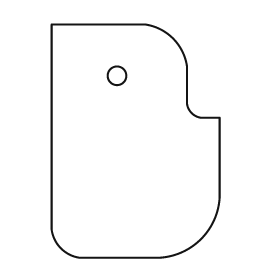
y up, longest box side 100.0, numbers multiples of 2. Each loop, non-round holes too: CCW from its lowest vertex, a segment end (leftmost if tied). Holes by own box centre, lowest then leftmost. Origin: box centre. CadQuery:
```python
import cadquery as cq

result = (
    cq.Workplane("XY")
    .moveTo(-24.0, -50.0)
    .lineTo(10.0, -50.0)
    .threePointArc((28.0, -42.0), (36.0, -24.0))
    .lineTo(36.0, 10.0)
    .lineTo(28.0, 10.0)
    .threePointArc((24.0, 12.0), (22.0, 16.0))
    .lineTo(22.0, 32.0)
    .threePointArc((16.0, 44.0), (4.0, 50.0))
    .lineTo(-36.0, 50.0)
    .lineTo(-36.0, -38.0)
    .threePointArc((-32.0, -46.0), (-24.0, -50.0))
    .close()
    .moveTo(-8.0, 28.0)
    .circle(4.0)
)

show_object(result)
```